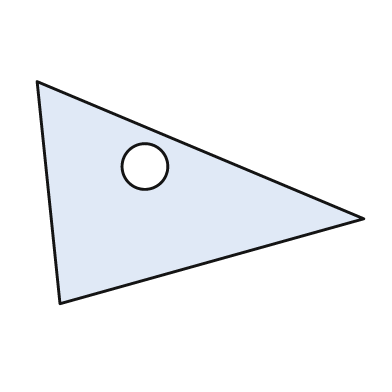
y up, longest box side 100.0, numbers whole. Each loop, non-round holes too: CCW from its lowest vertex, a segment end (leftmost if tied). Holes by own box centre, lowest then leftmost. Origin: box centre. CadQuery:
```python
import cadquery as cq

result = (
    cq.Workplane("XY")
    .moveTo(-43.0, -34.0)
    .lineTo(50.0, -8.0)
    .lineTo(-50.0, 34.0)
    .close()
    .moveTo(-17.0, 8.0)
    .circle(7.0)
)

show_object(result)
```